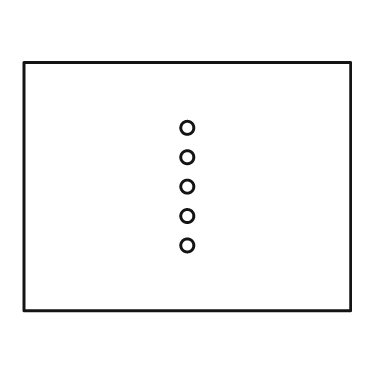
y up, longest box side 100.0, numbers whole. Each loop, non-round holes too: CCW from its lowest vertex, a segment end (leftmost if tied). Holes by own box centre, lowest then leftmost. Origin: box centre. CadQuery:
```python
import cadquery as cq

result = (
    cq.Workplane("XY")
    .moveTo(-50.0, -38.0)
    .lineTo(50.0, -38.0)
    .lineTo(50.0, 38.0)
    .lineTo(-50.0, 38.0)
    .close()
    .moveTo(0.0, -18.0)
    .circle(2.0)
    .moveTo(0.0, -9.0)
    .circle(2.0)
    .moveTo(0.0, 0.0)
    .circle(2.0)
    .moveTo(0.0, 9.0)
    .circle(2.0)
    .moveTo(0.0, 18.0)
    .circle(2.0)
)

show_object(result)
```